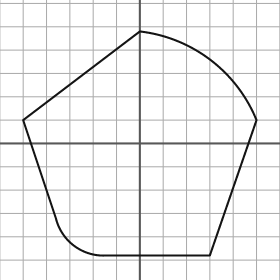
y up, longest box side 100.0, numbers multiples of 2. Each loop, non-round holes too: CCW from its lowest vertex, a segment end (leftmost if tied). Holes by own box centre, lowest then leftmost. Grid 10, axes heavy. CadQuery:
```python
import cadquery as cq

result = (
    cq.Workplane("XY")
    .moveTo(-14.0, -48.0)
    .lineTo(30.0, -48.0)
    .lineTo(50.0, 10.0)
    .threePointArc((30.0, 36.0), (0.0, 48.0))
    .lineTo(-50.0, 10.0)
    .lineTo(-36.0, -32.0)
    .threePointArc((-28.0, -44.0), (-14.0, -48.0))
    .close()
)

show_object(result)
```